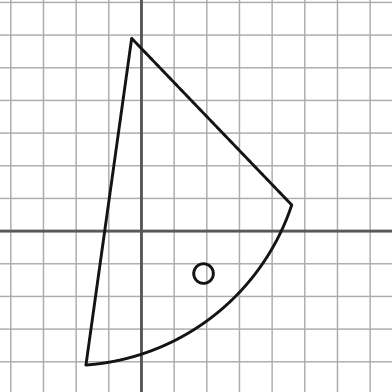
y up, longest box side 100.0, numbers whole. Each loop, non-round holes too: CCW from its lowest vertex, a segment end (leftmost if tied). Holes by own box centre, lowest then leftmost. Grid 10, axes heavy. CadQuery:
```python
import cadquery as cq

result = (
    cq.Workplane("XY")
    .moveTo(-17.0, -41.0)
    .threePointArc((22.0, -26.0), (46.0, 8.0))
    .lineTo(-3.0, 59.0)
    .close()
    .moveTo(19.0, -13.0)
    .circle(3.0)
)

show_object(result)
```